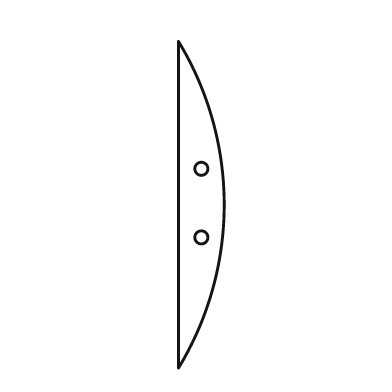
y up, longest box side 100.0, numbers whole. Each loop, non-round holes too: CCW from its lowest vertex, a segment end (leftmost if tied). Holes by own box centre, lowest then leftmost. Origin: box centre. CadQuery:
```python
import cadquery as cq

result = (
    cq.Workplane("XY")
    .moveTo(-7.0, -50.0)
    .threePointArc((7.0, 0.0), (-7.0, 50.0))
    .close()
    .moveTo(0.0, -10.0)
    .circle(2.0)
    .moveTo(0.0, 11.0)
    .circle(2.0)
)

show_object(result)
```